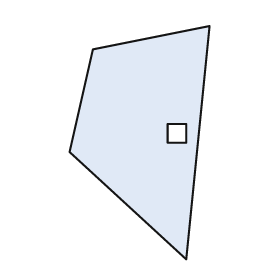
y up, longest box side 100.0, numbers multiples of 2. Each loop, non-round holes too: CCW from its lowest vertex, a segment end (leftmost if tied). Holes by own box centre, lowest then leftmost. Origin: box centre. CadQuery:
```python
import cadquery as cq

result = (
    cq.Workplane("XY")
    .moveTo(20.0, -50.0)
    .lineTo(30.0, 50.0)
    .lineTo(-20.0, 40.0)
    .lineTo(-30.0, -4.0)
    .close()
    .moveTo(12.0, 0.0)
    .lineTo(20.0, 0.0)
    .lineTo(20.0, 8.0)
    .lineTo(12.0, 8.0)
    .close()
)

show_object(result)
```